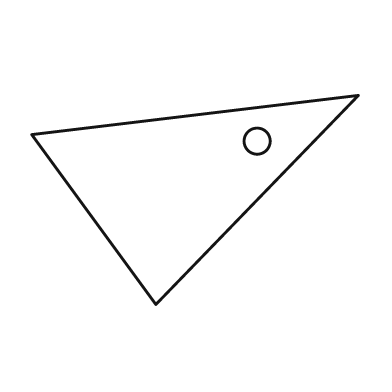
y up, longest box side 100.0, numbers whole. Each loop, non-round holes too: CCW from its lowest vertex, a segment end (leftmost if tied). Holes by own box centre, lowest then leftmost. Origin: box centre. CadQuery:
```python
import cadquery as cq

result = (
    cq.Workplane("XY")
    .moveTo(-12.0, -32.0)
    .lineTo(50.0, 32.0)
    .lineTo(-50.0, 20.0)
    .close()
    .moveTo(19.0, 18.0)
    .circle(4.0)
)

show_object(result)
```